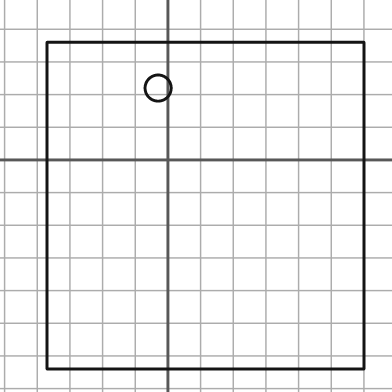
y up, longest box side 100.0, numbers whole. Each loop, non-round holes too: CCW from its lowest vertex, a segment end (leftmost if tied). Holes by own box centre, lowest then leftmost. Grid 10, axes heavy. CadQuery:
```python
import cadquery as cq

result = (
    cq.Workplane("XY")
    .moveTo(-37.0, -64.0)
    .lineTo(60.0, -64.0)
    .lineTo(60.0, 36.0)
    .lineTo(-37.0, 36.0)
    .close()
    .moveTo(-3.0, 22.0)
    .circle(4.0)
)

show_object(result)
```